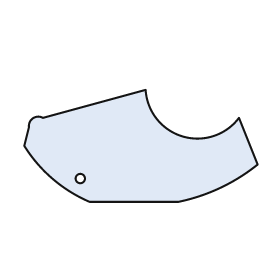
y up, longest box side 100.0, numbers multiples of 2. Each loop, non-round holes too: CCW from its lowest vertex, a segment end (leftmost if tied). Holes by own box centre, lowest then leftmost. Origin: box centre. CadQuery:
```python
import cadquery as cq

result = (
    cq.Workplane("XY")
    .moveTo(-22.0, -24.0)
    .lineTo(16.0, -24.0)
    .threePointArc((34.0, -18.0), (50.0, -8.0))
    .lineTo(42.0, 12.0)
    .threePointArc((18.0, 4.0), (2.0, 24.0))
    .lineTo(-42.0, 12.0)
    .threePointArc((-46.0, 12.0), (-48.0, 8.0))
    .lineTo(-50.0, 0.0)
    .threePointArc((-38.0, -14.0), (-22.0, -24.0))
    .close()
    .moveTo(-26.0, -14.0)
    .circle(2.0)
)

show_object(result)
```